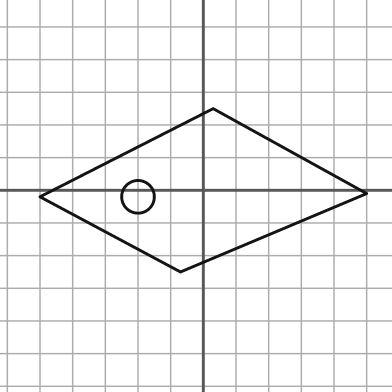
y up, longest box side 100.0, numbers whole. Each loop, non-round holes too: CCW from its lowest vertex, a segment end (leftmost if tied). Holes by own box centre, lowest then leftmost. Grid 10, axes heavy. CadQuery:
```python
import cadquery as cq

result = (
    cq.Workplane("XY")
    .moveTo(-7.0, -25.0)
    .lineTo(50.0, -1.0)
    .lineTo(3.0, 25.0)
    .lineTo(-50.0, -2.0)
    .close()
    .moveTo(-20.0, -2.0)
    .circle(5.0)
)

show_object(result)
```